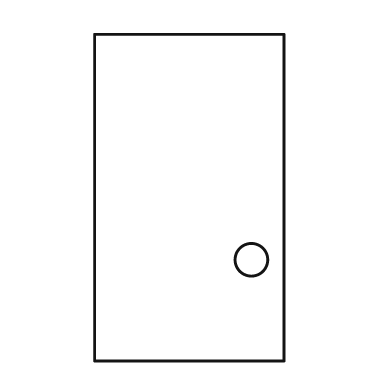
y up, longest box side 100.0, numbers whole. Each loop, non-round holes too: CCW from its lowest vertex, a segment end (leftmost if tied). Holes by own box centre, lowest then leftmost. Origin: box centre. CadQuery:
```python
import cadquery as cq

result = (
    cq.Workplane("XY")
    .moveTo(-29.0, -50.0)
    .lineTo(29.0, -50.0)
    .lineTo(29.0, 50.0)
    .lineTo(-29.0, 50.0)
    .close()
    .moveTo(19.0, -19.0)
    .circle(5.0)
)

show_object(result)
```